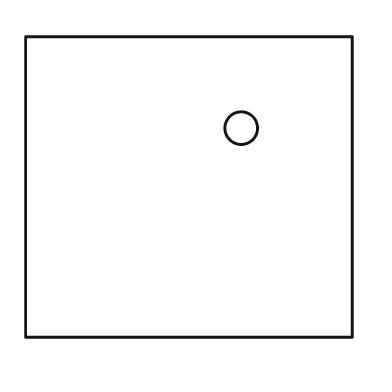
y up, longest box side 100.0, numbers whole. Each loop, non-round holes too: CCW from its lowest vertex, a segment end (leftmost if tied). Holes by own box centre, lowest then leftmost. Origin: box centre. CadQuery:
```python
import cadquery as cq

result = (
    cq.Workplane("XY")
    .moveTo(-50.0, -46.0)
    .lineTo(50.0, -46.0)
    .lineTo(50.0, 46.0)
    .lineTo(-50.0, 46.0)
    .close()
    .moveTo(16.0, 18.0)
    .circle(5.0)
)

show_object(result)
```